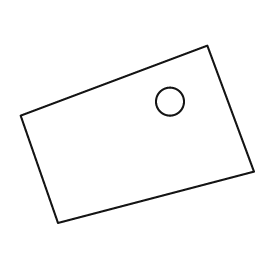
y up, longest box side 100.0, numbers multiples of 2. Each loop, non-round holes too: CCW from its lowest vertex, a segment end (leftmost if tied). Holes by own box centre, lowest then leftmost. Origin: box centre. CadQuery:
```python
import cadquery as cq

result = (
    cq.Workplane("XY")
    .moveTo(-34.0, -38.0)
    .lineTo(50.0, -16.0)
    .lineTo(30.0, 38.0)
    .lineTo(-50.0, 8.0)
    .close()
    .moveTo(14.0, 14.0)
    .circle(6.0)
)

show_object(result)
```